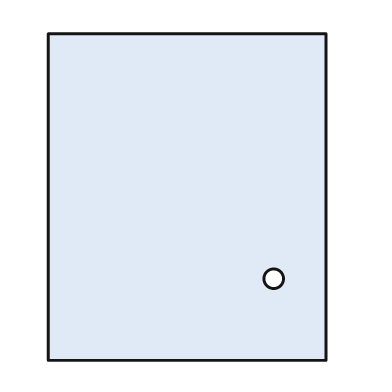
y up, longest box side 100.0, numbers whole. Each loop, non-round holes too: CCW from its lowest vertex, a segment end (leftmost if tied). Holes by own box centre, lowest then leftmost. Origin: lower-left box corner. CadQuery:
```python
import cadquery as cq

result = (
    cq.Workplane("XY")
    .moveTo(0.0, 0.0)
    .lineTo(85.0, 0.0)
    .lineTo(85.0, 100.0)
    .lineTo(0.0, 100.0)
    .close()
    .moveTo(69.0, 25.0)
    .circle(3.0)
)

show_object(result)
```